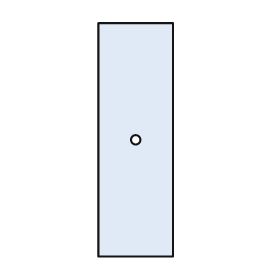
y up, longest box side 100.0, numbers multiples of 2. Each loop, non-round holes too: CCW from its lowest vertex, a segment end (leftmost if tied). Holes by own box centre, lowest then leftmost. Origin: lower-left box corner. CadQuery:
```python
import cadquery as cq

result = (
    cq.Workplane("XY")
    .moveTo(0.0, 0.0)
    .lineTo(32.0, 0.0)
    .lineTo(32.0, 100.0)
    .lineTo(0.0, 100.0)
    .close()
    .moveTo(16.0, 50.0)
    .circle(2.0)
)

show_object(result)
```